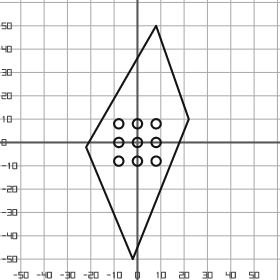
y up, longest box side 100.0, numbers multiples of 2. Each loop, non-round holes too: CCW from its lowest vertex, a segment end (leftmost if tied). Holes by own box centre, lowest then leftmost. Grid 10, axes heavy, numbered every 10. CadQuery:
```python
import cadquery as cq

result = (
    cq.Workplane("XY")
    .moveTo(-2.0, -50.0)
    .lineTo(22.0, 10.0)
    .lineTo(8.0, 50.0)
    .lineTo(-22.0, -2.0)
    .close()
    .moveTo(-8.0, -8.0)
    .circle(2.0)
    .moveTo(0.0, -8.0)
    .circle(2.0)
    .moveTo(8.0, -8.0)
    .circle(2.0)
    .moveTo(-8.0, 0.0)
    .circle(2.0)
    .moveTo(0.0, 0.0)
    .circle(2.0)
    .moveTo(8.0, 0.0)
    .circle(2.0)
    .moveTo(-8.0, 8.0)
    .circle(2.0)
    .moveTo(0.0, 8.0)
    .circle(2.0)
    .moveTo(8.0, 8.0)
    .circle(2.0)
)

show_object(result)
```